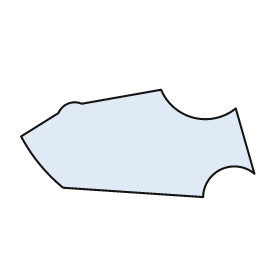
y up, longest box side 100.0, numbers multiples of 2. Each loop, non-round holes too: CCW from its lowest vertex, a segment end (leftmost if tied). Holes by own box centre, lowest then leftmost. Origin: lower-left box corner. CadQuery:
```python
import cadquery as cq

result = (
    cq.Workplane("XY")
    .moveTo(78.0, 0.0)
    .threePointArc((86.0, 12.0), (100.0, 10.0))
    .lineTo(92.0, 38.0)
    .threePointArc((74.0, 34.0), (60.0, 46.0))
    .lineTo(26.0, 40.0)
    .threePointArc((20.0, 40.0), (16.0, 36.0))
    .lineTo(0.0, 26.0)
    .threePointArc((8.0, 14.0), (18.0, 4.0))
    .close()
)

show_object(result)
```